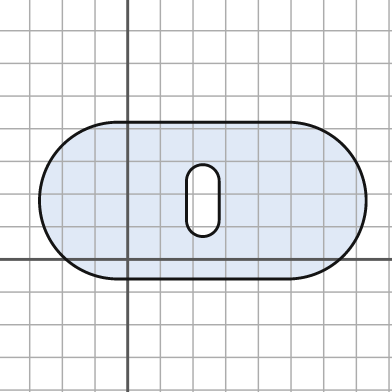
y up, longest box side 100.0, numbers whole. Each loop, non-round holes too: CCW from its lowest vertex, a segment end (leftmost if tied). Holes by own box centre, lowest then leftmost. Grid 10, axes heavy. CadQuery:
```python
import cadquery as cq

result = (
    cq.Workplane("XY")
    .moveTo(-3.0, -6.0)
    .lineTo(49.0, -6.0)
    .threePointArc((73.0, 18.0), (49.0, 42.0))
    .lineTo(-3.0, 42.0)
    .threePointArc((-27.0, 18.0), (-3.0, -6.0))
    .close()
    .moveTo(18.0, 12.0)
    .threePointArc((23.0, 7.0), (28.0, 12.0))
    .lineTo(28.0, 24.0)
    .threePointArc((23.0, 29.0), (18.0, 24.0))
    .close()
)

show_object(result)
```